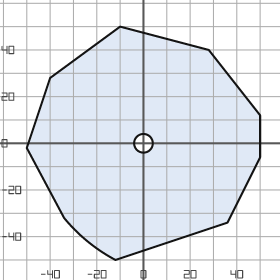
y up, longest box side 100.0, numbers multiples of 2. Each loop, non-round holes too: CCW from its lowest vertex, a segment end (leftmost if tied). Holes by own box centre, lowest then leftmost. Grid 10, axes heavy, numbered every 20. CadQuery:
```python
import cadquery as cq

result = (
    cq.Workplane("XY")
    .moveTo(-12.0, -50.0)
    .lineTo(36.0, -34.0)
    .lineTo(50.0, -6.0)
    .lineTo(50.0, 12.0)
    .lineTo(28.0, 40.0)
    .lineTo(-10.0, 50.0)
    .lineTo(-40.0, 28.0)
    .lineTo(-50.0, -2.0)
    .lineTo(-34.0, -32.0)
    .threePointArc((-24.0, -42.0), (-12.0, -50.0))
    .close()
    .moveTo(0.0, 0.0)
    .circle(4.0)
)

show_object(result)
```